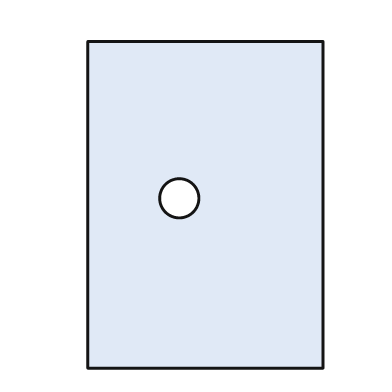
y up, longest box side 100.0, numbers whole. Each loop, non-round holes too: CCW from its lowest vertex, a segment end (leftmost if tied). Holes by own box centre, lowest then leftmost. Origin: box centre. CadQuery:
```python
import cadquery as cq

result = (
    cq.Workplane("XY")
    .moveTo(-36.0, -50.0)
    .lineTo(36.0, -50.0)
    .lineTo(36.0, 50.0)
    .lineTo(-36.0, 50.0)
    .close()
    .moveTo(-8.0, 2.0)
    .circle(6.0)
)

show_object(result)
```